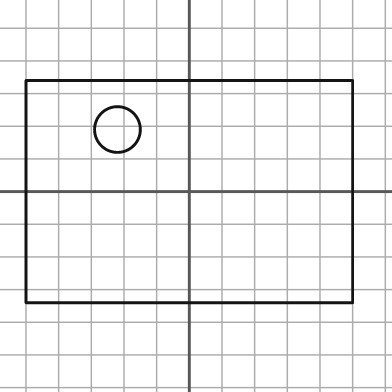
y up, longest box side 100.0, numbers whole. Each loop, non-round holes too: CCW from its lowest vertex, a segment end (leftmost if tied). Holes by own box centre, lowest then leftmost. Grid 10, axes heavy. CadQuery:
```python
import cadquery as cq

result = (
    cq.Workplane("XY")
    .moveTo(-50.0, -34.0)
    .lineTo(50.0, -34.0)
    .lineTo(50.0, 34.0)
    .lineTo(-50.0, 34.0)
    .close()
    .moveTo(-22.0, 19.0)
    .circle(7.0)
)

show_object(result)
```